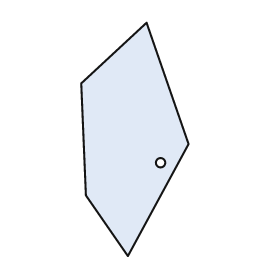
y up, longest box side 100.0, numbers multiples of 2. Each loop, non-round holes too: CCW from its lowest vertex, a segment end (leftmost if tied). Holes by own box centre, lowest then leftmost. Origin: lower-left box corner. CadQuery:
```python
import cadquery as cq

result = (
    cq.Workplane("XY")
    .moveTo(20.0, 0.0)
    .lineTo(46.0, 48.0)
    .lineTo(28.0, 100.0)
    .lineTo(0.0, 74.0)
    .lineTo(2.0, 26.0)
    .close()
    .moveTo(34.0, 40.0)
    .circle(2.0)
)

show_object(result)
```